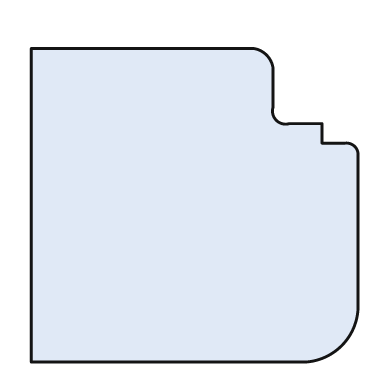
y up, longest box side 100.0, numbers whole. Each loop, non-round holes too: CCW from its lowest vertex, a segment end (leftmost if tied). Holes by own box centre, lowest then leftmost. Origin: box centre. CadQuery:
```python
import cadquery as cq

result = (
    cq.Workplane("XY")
    .moveTo(-50.0, -48.0)
    .lineTo(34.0, -48.0)
    .threePointArc((45.0, -43.0), (50.0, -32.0))
    .lineTo(50.0, 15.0)
    .threePointArc((49.0, 18.0), (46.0, 19.0))
    .lineTo(39.0, 19.0)
    .lineTo(39.0, 25.0)
    .lineTo(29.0, 25.0)
    .threePointArc((25.0, 26.0), (24.0, 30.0))
    .lineTo(24.0, 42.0)
    .threePointArc((22.0, 46.0), (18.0, 48.0))
    .lineTo(-50.0, 48.0)
    .close()
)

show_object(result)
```